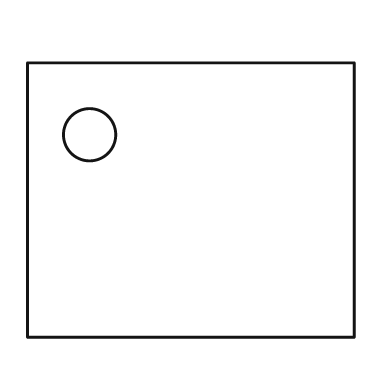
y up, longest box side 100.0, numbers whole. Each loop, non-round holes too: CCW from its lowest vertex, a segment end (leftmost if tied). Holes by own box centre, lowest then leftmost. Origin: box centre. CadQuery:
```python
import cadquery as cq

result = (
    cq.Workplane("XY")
    .moveTo(-50.0, -42.0)
    .lineTo(50.0, -42.0)
    .lineTo(50.0, 42.0)
    .lineTo(-50.0, 42.0)
    .close()
    .moveTo(-31.0, 20.0)
    .circle(8.0)
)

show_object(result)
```